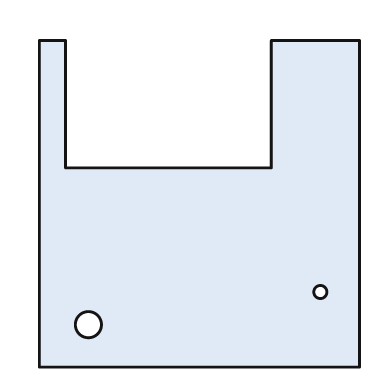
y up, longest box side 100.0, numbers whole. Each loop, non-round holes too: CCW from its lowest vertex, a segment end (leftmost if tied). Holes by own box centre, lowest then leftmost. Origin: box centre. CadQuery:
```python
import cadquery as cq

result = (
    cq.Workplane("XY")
    .moveTo(-49.0, -50.0)
    .lineTo(49.0, -50.0)
    .lineTo(49.0, 50.0)
    .lineTo(22.0, 50.0)
    .lineTo(22.0, 11.0)
    .lineTo(-41.0, 11.0)
    .lineTo(-41.0, 50.0)
    .lineTo(-49.0, 50.0)
    .close()
    .moveTo(-34.0, -37.0)
    .circle(4.0)
    .moveTo(37.0, -27.0)
    .circle(2.0)
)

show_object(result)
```